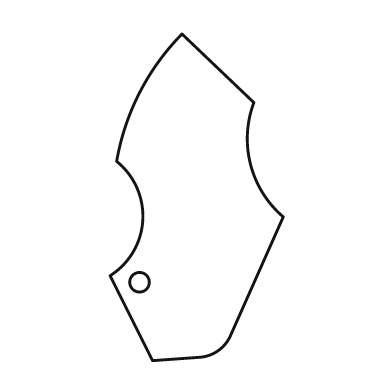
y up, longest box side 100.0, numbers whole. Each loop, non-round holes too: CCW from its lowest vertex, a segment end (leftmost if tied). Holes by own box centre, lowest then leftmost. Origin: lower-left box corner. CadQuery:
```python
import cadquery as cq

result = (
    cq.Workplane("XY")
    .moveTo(13.0, 0.0)
    .lineTo(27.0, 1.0)
    .threePointArc((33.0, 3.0), (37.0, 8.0))
    .lineTo(53.0, 44.0)
    .threePointArc((43.0, 60.0), (44.0, 79.0))
    .lineTo(22.0, 100.0)
    .threePointArc((9.0, 82.0), (2.0, 61.0))
    .threePointArc((10.0, 43.0), (0.0, 26.0))
    .close()
    .moveTo(9.0, 24.0)
    .circle(3.0)
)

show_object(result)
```